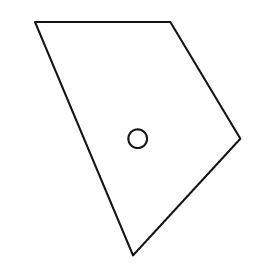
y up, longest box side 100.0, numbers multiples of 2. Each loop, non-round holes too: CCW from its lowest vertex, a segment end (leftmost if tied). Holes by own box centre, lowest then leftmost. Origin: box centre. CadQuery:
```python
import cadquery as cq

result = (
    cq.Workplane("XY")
    .moveTo(-2.0, -50.0)
    .lineTo(44.0, 0.0)
    .lineTo(14.0, 50.0)
    .lineTo(-44.0, 50.0)
    .close()
    .moveTo(0.0, 0.0)
    .circle(4.0)
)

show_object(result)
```